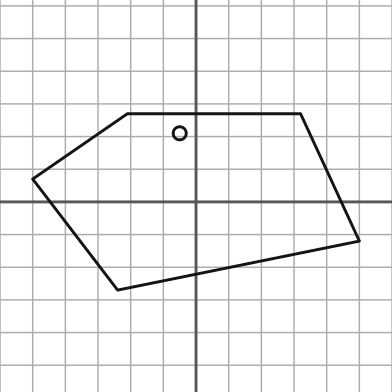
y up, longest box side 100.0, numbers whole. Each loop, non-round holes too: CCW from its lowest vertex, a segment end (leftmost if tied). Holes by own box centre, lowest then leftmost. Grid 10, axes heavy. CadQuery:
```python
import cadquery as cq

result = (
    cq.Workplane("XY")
    .moveTo(-24.0, -27.0)
    .lineTo(50.0, -12.0)
    .lineTo(32.0, 27.0)
    .lineTo(-21.0, 27.0)
    .lineTo(-50.0, 7.0)
    .close()
    .moveTo(-5.0, 21.0)
    .circle(2.0)
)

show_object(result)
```